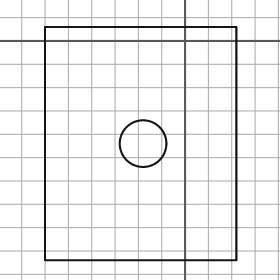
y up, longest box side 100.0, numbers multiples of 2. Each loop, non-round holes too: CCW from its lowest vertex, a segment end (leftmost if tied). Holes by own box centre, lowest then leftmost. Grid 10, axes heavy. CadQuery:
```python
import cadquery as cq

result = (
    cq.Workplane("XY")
    .moveTo(-60.0, -94.0)
    .lineTo(22.0, -94.0)
    .lineTo(22.0, 6.0)
    .lineTo(-60.0, 6.0)
    .close()
    .moveTo(-18.0, -44.0)
    .circle(10.0)
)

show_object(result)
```